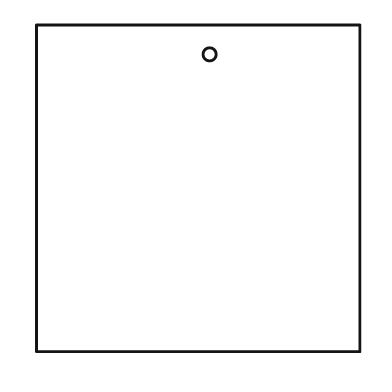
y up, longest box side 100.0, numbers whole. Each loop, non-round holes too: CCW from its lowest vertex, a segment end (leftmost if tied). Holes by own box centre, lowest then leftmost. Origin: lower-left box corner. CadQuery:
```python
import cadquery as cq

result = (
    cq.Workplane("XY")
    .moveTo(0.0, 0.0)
    .lineTo(99.0, 0.0)
    .lineTo(99.0, 100.0)
    .lineTo(0.0, 100.0)
    .close()
    .moveTo(53.0, 91.0)
    .circle(2.0)
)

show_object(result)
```